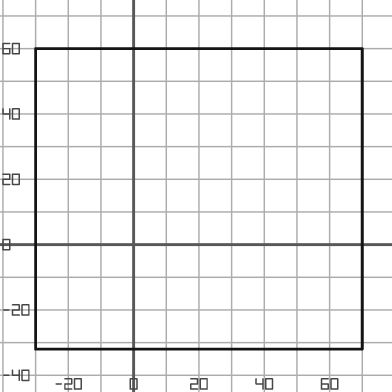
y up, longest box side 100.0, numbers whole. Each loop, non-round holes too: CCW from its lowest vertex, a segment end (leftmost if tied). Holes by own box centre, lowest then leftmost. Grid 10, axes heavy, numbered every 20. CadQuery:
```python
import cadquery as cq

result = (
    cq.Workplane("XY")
    .moveTo(-30.0, -32.0)
    .lineTo(70.0, -32.0)
    .lineTo(70.0, 60.0)
    .lineTo(-30.0, 60.0)
    .close()
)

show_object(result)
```